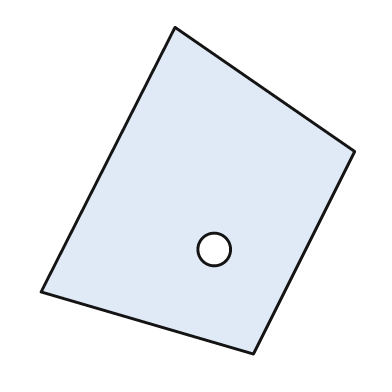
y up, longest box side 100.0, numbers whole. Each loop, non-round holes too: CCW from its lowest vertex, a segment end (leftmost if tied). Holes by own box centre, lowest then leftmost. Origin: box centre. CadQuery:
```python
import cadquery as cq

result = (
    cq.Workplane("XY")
    .moveTo(17.0, -50.0)
    .lineTo(48.0, 12.0)
    .lineTo(-7.0, 50.0)
    .lineTo(-48.0, -31.0)
    .close()
    .moveTo(5.0, -18.0)
    .circle(5.0)
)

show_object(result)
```